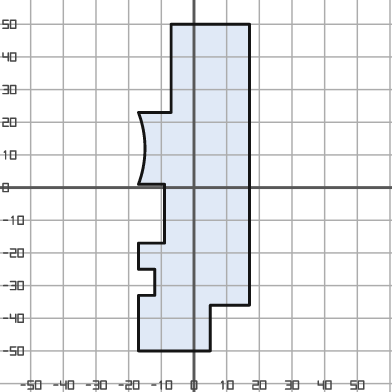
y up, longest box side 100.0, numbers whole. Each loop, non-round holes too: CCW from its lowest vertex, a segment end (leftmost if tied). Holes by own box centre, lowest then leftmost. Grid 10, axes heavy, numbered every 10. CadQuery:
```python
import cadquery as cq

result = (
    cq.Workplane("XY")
    .moveTo(-17.0, -50.0)
    .lineTo(5.0, -50.0)
    .lineTo(5.0, -36.0)
    .lineTo(17.0, -36.0)
    .lineTo(17.0, 50.0)
    .lineTo(-7.0, 50.0)
    .lineTo(-7.0, 23.0)
    .lineTo(-17.0, 23.0)
    .threePointArc((-15.0, 12.0), (-17.0, 1.0))
    .lineTo(-9.0, 1.0)
    .lineTo(-9.0, -17.0)
    .lineTo(-17.0, -17.0)
    .lineTo(-17.0, -25.0)
    .lineTo(-12.0, -25.0)
    .lineTo(-12.0, -33.0)
    .lineTo(-17.0, -33.0)
    .close()
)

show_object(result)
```